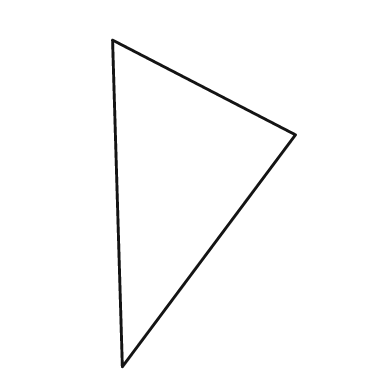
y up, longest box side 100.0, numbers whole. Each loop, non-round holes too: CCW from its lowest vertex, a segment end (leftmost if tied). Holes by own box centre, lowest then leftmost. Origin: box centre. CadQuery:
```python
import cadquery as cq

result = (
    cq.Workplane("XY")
    .moveTo(-25.0, -50.0)
    .lineTo(28.0, 21.0)
    .lineTo(-28.0, 50.0)
    .close()
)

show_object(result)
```